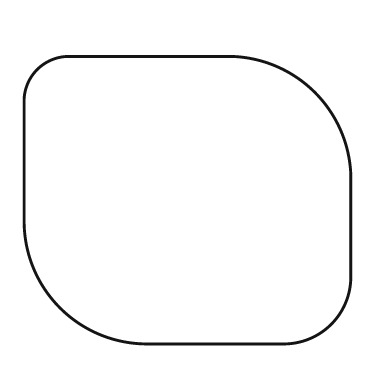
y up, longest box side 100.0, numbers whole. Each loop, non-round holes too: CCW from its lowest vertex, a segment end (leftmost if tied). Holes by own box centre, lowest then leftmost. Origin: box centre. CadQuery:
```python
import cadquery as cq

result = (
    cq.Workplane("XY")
    .moveTo(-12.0, -44.0)
    .lineTo(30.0, -44.0)
    .threePointArc((44.0, -38.0), (50.0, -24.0))
    .lineTo(50.0, 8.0)
    .threePointArc((39.0, 33.0), (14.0, 44.0))
    .lineTo(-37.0, 44.0)
    .threePointArc((-46.0, 40.0), (-50.0, 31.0))
    .lineTo(-50.0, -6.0)
    .threePointArc((-39.0, -33.0), (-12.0, -44.0))
    .close()
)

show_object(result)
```